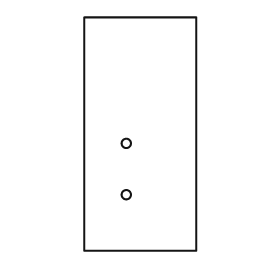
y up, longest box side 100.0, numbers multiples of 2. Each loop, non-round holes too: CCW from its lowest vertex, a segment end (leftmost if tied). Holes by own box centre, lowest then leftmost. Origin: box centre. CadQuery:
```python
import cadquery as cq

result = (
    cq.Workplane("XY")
    .moveTo(-24.0, -50.0)
    .lineTo(24.0, -50.0)
    .lineTo(24.0, 50.0)
    .lineTo(-24.0, 50.0)
    .close()
    .moveTo(-6.0, -26.0)
    .circle(2.0)
    .moveTo(-6.0, -4.0)
    .circle(2.0)
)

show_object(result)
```